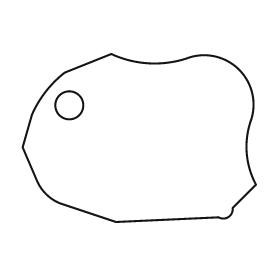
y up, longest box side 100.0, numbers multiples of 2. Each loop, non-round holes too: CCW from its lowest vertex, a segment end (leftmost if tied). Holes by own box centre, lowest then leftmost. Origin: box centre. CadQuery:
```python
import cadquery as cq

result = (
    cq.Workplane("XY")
    .moveTo(-10.0, -36.0)
    .lineTo(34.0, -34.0)
    .threePointArc((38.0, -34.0), (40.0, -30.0))
    .lineTo(50.0, -20.0)
    .threePointArc((46.0, -6.0), (48.0, 8.0))
    .threePointArc((42.0, 30.0), (20.0, 34.0))
    .threePointArc((4.0, 32.0), (-12.0, 36.0))
    .lineTo(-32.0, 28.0)
    .threePointArc((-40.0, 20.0), (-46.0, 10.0))
    .lineTo(-50.0, -4.0)
    .lineTo(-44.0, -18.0)
    .threePointArc((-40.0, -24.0), (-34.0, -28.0))
    .close()
    .moveTo(-30.0, 14.0)
    .circle(6.0)
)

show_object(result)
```